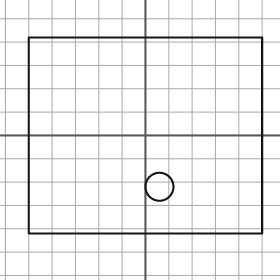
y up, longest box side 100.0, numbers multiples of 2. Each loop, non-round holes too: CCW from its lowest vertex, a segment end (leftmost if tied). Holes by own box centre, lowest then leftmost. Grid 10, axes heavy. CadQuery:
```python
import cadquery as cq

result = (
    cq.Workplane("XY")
    .moveTo(-50.0, -42.0)
    .lineTo(50.0, -42.0)
    .lineTo(50.0, 42.0)
    .lineTo(-50.0, 42.0)
    .close()
    .moveTo(6.0, -22.0)
    .circle(6.0)
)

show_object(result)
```